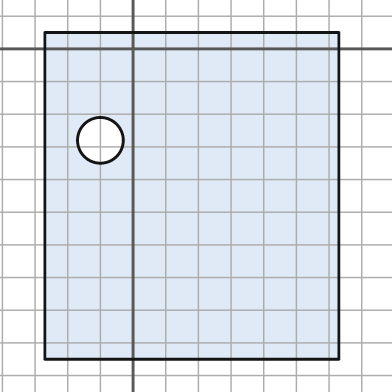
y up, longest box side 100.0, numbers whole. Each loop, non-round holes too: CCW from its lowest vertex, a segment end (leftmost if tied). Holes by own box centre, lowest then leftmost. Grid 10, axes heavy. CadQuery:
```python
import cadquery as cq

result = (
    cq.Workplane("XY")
    .moveTo(-27.0, -95.0)
    .lineTo(63.0, -95.0)
    .lineTo(63.0, 5.0)
    .lineTo(-27.0, 5.0)
    .close()
    .moveTo(-10.0, -28.0)
    .circle(7.0)
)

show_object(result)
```